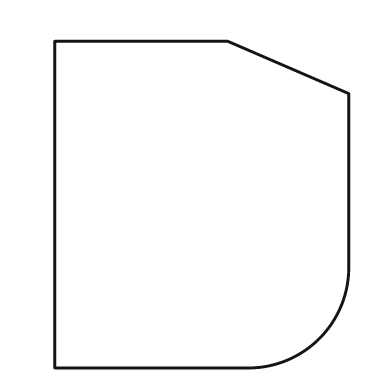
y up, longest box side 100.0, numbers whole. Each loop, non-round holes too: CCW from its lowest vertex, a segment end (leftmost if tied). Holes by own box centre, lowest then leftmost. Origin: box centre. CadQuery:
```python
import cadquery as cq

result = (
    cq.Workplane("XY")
    .moveTo(-45.0, -50.0)
    .lineTo(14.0, -50.0)
    .threePointArc((36.0, -41.0), (45.0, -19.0))
    .lineTo(45.0, 34.0)
    .lineTo(8.0, 50.0)
    .lineTo(-45.0, 50.0)
    .close()
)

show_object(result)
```